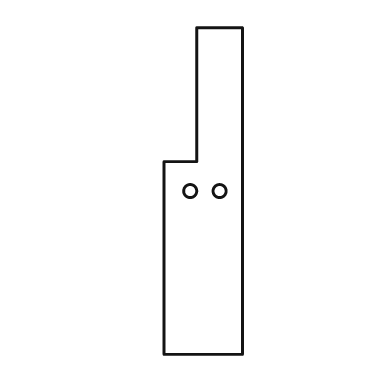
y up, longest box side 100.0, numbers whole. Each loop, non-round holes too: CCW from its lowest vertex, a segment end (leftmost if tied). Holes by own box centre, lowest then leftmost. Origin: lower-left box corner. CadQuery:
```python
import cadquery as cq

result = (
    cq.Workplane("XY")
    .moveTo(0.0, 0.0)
    .lineTo(24.0, 0.0)
    .lineTo(24.0, 100.0)
    .lineTo(10.0, 100.0)
    .lineTo(10.0, 59.0)
    .lineTo(0.0, 59.0)
    .close()
    .moveTo(8.0, 50.0)
    .circle(2.0)
    .moveTo(17.0, 50.0)
    .circle(2.0)
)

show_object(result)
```